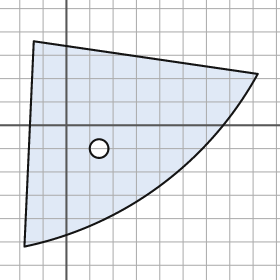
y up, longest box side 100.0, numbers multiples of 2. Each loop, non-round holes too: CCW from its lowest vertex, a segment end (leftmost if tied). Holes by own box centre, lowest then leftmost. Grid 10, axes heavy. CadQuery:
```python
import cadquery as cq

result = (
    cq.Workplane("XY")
    .moveTo(-18.0, -52.0)
    .threePointArc((40.0, -26.0), (82.0, 22.0))
    .lineTo(-14.0, 36.0)
    .close()
    .moveTo(14.0, -10.0)
    .circle(4.0)
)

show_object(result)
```